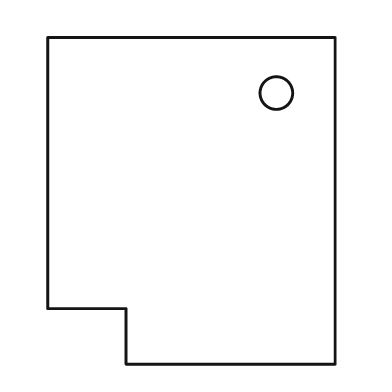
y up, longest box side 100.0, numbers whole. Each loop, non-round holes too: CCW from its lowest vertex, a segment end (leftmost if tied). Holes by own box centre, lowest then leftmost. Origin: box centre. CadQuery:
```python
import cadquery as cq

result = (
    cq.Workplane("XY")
    .moveTo(-20.0, -50.0)
    .lineTo(44.0, -50.0)
    .lineTo(44.0, 50.0)
    .lineTo(-44.0, 50.0)
    .lineTo(-44.0, -33.0)
    .lineTo(-20.0, -33.0)
    .close()
    .moveTo(26.0, 33.0)
    .circle(5.0)
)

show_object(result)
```